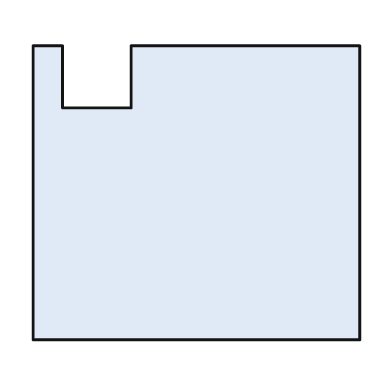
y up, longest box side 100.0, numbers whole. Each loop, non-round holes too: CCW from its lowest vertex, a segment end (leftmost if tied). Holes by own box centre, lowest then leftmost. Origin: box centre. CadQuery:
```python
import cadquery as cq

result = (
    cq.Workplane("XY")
    .moveTo(-50.0, -45.0)
    .lineTo(50.0, -45.0)
    .lineTo(50.0, 45.0)
    .lineTo(-20.0, 45.0)
    .lineTo(-20.0, 26.0)
    .lineTo(-41.0, 26.0)
    .lineTo(-41.0, 45.0)
    .lineTo(-50.0, 45.0)
    .close()
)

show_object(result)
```